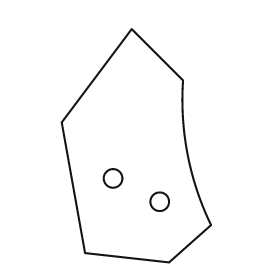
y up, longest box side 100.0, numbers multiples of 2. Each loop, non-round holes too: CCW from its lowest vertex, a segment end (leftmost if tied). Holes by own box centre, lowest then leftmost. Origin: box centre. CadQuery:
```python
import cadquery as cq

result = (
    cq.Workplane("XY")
    .moveTo(14.0, -50.0)
    .lineTo(32.0, -34.0)
    .threePointArc((22.0, -4.0), (20.0, 28.0))
    .lineTo(-2.0, 50.0)
    .lineTo(-32.0, 10.0)
    .lineTo(-22.0, -46.0)
    .close()
    .moveTo(10.0, -24.0)
    .circle(4.0)
    .moveTo(-10.0, -14.0)
    .circle(4.0)
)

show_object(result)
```